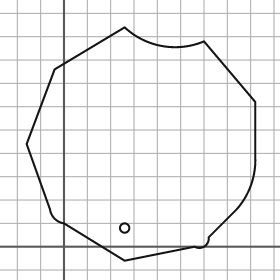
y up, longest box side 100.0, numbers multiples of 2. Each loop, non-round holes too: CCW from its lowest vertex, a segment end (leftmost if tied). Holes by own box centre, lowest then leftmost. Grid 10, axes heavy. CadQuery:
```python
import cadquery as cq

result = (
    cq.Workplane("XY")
    .moveTo(26.0, -6.0)
    .lineTo(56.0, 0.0)
    .threePointArc((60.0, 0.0), (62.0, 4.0))
    .lineTo(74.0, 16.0)
    .threePointArc((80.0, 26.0), (82.0, 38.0))
    .lineTo(82.0, 62.0)
    .lineTo(60.0, 88.0)
    .threePointArc((42.0, 86.0), (26.0, 94.0))
    .lineTo(-4.0, 76.0)
    .lineTo(-16.0, 44.0)
    .lineTo(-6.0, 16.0)
    .threePointArc((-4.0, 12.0), (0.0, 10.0))
    .close()
    .moveTo(26.0, 8.0)
    .circle(2.0)
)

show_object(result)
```